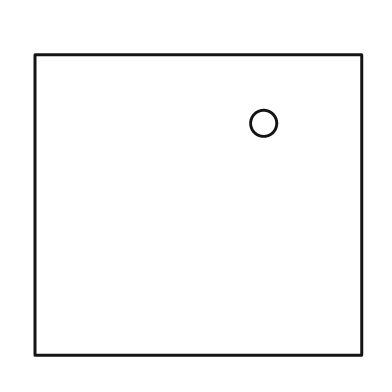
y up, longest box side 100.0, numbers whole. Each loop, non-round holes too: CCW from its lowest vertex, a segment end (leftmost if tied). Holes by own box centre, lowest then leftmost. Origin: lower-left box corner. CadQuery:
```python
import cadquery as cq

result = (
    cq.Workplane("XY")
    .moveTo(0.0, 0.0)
    .lineTo(100.0, 0.0)
    .lineTo(100.0, 92.0)
    .lineTo(0.0, 92.0)
    .close()
    .moveTo(70.0, 71.0)
    .circle(4.0)
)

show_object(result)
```